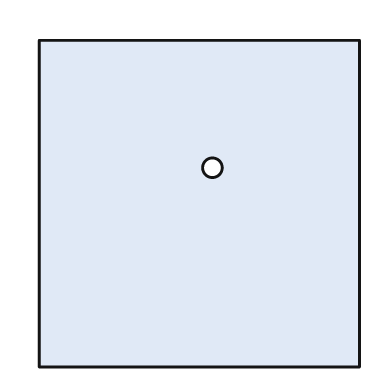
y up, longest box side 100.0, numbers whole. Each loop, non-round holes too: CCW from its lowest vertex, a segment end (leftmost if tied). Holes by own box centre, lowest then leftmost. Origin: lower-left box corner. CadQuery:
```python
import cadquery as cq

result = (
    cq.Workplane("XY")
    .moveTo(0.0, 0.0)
    .lineTo(98.0, 0.0)
    .lineTo(98.0, 100.0)
    .lineTo(0.0, 100.0)
    .close()
    .moveTo(53.0, 61.0)
    .circle(3.0)
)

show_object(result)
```